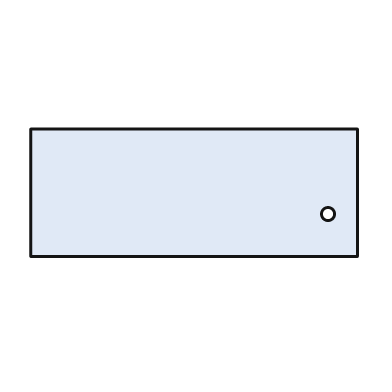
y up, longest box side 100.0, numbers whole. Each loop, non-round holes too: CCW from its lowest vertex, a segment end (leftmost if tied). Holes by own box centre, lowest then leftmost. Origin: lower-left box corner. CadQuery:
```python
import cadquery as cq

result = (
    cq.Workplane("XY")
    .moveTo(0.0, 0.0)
    .lineTo(100.0, 0.0)
    .lineTo(100.0, 39.0)
    .lineTo(0.0, 39.0)
    .close()
    .moveTo(91.0, 13.0)
    .circle(2.0)
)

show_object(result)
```